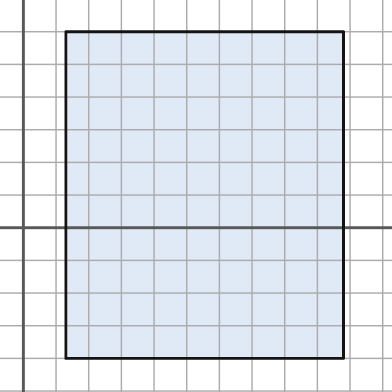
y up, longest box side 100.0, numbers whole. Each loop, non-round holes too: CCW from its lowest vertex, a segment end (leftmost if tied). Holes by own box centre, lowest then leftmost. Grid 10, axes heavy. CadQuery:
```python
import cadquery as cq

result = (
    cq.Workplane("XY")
    .moveTo(13.0, -40.0)
    .lineTo(98.0, -40.0)
    .lineTo(98.0, 60.0)
    .lineTo(13.0, 60.0)
    .close()
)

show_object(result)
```